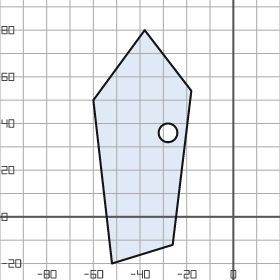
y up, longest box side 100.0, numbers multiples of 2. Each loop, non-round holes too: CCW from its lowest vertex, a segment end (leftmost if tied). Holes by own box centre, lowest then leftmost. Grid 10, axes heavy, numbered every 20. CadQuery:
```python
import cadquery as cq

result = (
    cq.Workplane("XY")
    .moveTo(-52.0, -20.0)
    .lineTo(-26.0, -12.0)
    .lineTo(-18.0, 54.0)
    .lineTo(-38.0, 80.0)
    .lineTo(-60.0, 50.0)
    .close()
    .moveTo(-28.0, 36.0)
    .circle(4.0)
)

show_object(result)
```